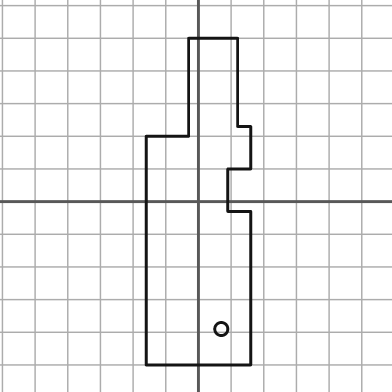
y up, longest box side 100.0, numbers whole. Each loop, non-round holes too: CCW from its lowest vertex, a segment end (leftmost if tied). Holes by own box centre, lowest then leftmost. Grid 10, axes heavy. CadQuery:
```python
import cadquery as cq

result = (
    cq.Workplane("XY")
    .moveTo(-16.0, -50.0)
    .lineTo(16.0, -50.0)
    .lineTo(16.0, -3.0)
    .lineTo(9.0, -3.0)
    .lineTo(9.0, 10.0)
    .lineTo(16.0, 10.0)
    .lineTo(16.0, 23.0)
    .lineTo(12.0, 23.0)
    .lineTo(12.0, 50.0)
    .lineTo(-3.0, 50.0)
    .lineTo(-3.0, 20.0)
    .lineTo(-16.0, 20.0)
    .close()
    .moveTo(7.0, -39.0)
    .circle(2.0)
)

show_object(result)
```